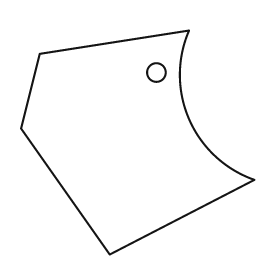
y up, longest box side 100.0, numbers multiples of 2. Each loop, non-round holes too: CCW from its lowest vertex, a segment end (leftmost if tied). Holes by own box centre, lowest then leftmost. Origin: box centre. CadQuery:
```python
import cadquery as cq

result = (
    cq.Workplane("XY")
    .moveTo(-12.0, -48.0)
    .lineTo(50.0, -16.0)
    .threePointArc((22.0, 10.0), (22.0, 48.0))
    .lineTo(-42.0, 38.0)
    .lineTo(-50.0, 6.0)
    .close()
    .moveTo(8.0, 30.0)
    .circle(4.0)
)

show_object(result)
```